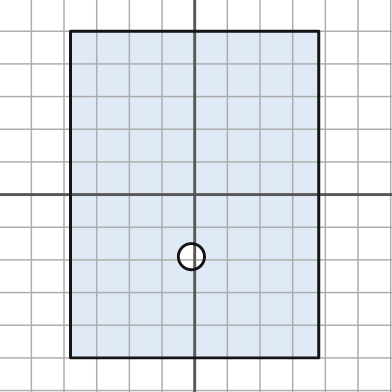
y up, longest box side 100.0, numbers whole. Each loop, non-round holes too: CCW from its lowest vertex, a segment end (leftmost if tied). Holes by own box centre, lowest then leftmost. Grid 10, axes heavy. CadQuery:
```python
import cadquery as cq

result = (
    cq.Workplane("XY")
    .moveTo(-38.0, -50.0)
    .lineTo(38.0, -50.0)
    .lineTo(38.0, 50.0)
    .lineTo(-38.0, 50.0)
    .close()
    .moveTo(-1.0, -19.0)
    .circle(4.0)
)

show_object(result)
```